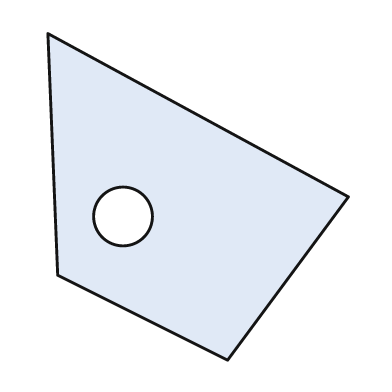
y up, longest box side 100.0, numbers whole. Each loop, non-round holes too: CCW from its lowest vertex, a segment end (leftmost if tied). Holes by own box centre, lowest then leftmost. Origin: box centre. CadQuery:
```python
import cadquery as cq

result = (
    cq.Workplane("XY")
    .moveTo(9.0, -50.0)
    .lineTo(46.0, 0.0)
    .lineTo(-46.0, 50.0)
    .lineTo(-43.0, -24.0)
    .close()
    .moveTo(-23.0, -6.0)
    .circle(9.0)
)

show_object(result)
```